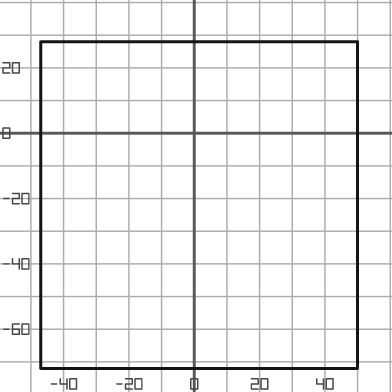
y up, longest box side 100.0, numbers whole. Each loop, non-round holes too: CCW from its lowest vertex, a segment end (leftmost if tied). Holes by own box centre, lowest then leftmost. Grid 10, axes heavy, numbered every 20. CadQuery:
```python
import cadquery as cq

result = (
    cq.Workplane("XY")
    .moveTo(-47.0, -72.0)
    .lineTo(50.0, -72.0)
    .lineTo(50.0, 28.0)
    .lineTo(-47.0, 28.0)
    .close()
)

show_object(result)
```